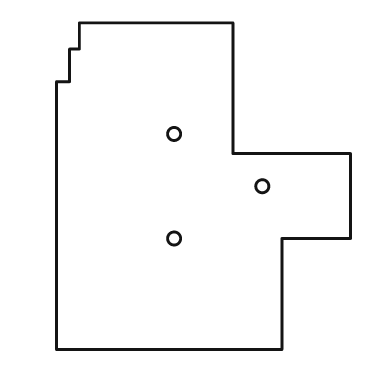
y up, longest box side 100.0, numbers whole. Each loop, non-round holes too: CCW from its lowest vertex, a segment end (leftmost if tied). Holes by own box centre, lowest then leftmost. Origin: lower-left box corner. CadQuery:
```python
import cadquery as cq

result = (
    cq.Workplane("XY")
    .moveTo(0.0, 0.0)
    .lineTo(69.0, 0.0)
    .lineTo(69.0, 34.0)
    .lineTo(90.0, 34.0)
    .lineTo(90.0, 60.0)
    .lineTo(54.0, 60.0)
    .lineTo(54.0, 100.0)
    .lineTo(7.0, 100.0)
    .lineTo(7.0, 92.0)
    .lineTo(4.0, 92.0)
    .lineTo(4.0, 82.0)
    .lineTo(0.0, 82.0)
    .close()
    .moveTo(36.0, 34.0)
    .circle(2.0)
    .moveTo(63.0, 50.0)
    .circle(2.0)
    .moveTo(36.0, 66.0)
    .circle(2.0)
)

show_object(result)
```